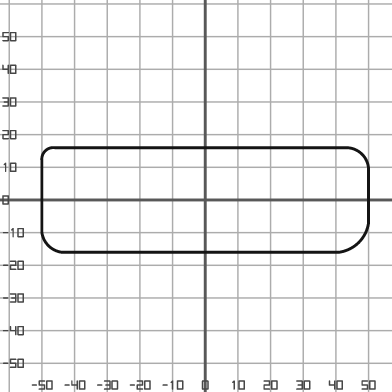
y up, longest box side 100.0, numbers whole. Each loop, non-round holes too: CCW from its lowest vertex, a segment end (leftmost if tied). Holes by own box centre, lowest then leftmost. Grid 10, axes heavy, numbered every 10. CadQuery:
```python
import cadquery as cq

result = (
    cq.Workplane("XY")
    .moveTo(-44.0, -16.0)
    .lineTo(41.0, -16.0)
    .threePointArc((47.0, -13.0), (50.0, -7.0))
    .lineTo(50.0, 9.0)
    .threePointArc((48.0, 14.0), (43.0, 16.0))
    .lineTo(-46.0, 16.0)
    .threePointArc((-49.0, 15.0), (-50.0, 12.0))
    .lineTo(-50.0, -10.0)
    .threePointArc((-48.0, -14.0), (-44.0, -16.0))
    .close()
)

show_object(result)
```